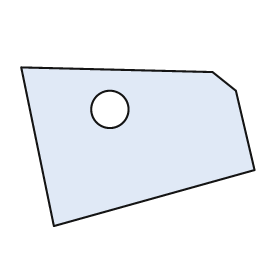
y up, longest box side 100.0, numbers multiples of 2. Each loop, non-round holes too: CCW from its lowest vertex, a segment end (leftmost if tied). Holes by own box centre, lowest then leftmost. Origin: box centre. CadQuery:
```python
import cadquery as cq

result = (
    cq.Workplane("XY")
    .moveTo(-36.0, -34.0)
    .lineTo(50.0, -10.0)
    .lineTo(42.0, 24.0)
    .lineTo(32.0, 32.0)
    .lineTo(-50.0, 34.0)
    .close()
    .moveTo(-12.0, 16.0)
    .circle(8.0)
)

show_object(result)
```